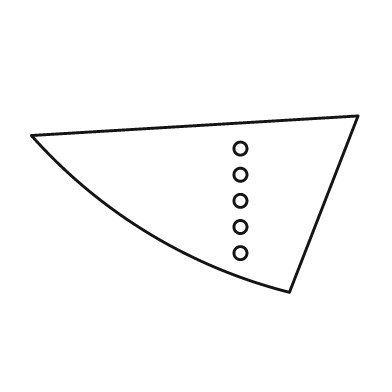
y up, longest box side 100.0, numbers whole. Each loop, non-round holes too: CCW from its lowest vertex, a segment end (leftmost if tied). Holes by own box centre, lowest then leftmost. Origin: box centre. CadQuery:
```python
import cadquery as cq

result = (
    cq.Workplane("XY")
    .moveTo(29.0, -27.0)
    .lineTo(50.0, 27.0)
    .lineTo(-50.0, 21.0)
    .threePointArc((-14.0, -9.0), (29.0, -27.0))
    .close()
    .moveTo(14.0, -15.0)
    .circle(2.0)
    .moveTo(14.0, -7.0)
    .circle(2.0)
    .moveTo(14.0, 1.0)
    .circle(2.0)
    .moveTo(14.0, 9.0)
    .circle(2.0)
    .moveTo(14.0, 17.0)
    .circle(2.0)
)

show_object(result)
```